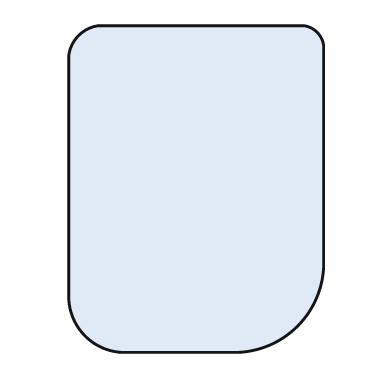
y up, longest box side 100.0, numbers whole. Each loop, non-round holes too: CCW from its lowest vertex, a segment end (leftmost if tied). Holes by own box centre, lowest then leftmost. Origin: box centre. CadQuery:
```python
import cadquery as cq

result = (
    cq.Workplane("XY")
    .moveTo(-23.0, -50.0)
    .lineTo(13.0, -50.0)
    .threePointArc((31.0, -42.0), (39.0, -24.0))
    .lineTo(39.0, 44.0)
    .threePointArc((37.0, 48.0), (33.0, 50.0))
    .lineTo(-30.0, 50.0)
    .threePointArc((-36.0, 47.0), (-39.0, 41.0))
    .lineTo(-39.0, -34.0)
    .threePointArc((-34.0, -45.0), (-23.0, -50.0))
    .close()
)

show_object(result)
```